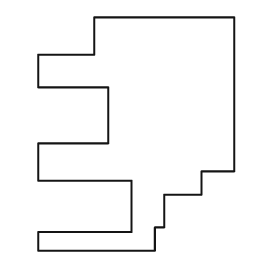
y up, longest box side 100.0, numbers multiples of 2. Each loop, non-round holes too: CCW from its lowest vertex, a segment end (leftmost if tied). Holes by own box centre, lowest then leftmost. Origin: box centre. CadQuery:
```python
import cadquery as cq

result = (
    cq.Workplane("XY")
    .moveTo(-42.0, -50.0)
    .lineTo(8.0, -50.0)
    .lineTo(8.0, -40.0)
    .lineTo(12.0, -40.0)
    .lineTo(12.0, -26.0)
    .lineTo(28.0, -26.0)
    .lineTo(28.0, -16.0)
    .lineTo(42.0, -16.0)
    .lineTo(42.0, 50.0)
    .lineTo(-18.0, 50.0)
    .lineTo(-18.0, 34.0)
    .lineTo(-42.0, 34.0)
    .lineTo(-42.0, 20.0)
    .lineTo(-12.0, 20.0)
    .lineTo(-12.0, -4.0)
    .lineTo(-42.0, -4.0)
    .lineTo(-42.0, -20.0)
    .lineTo(-2.0, -20.0)
    .lineTo(-2.0, -42.0)
    .lineTo(-42.0, -42.0)
    .close()
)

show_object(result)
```